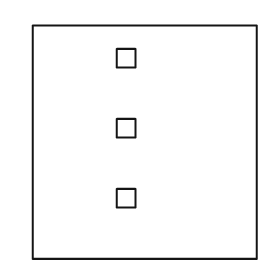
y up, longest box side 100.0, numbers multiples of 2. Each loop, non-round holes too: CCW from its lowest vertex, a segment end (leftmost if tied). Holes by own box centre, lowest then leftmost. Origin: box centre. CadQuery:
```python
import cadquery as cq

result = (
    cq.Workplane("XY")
    .moveTo(-48.0, -50.0)
    .lineTo(48.0, -50.0)
    .lineTo(48.0, 50.0)
    .lineTo(-48.0, 50.0)
    .close()
    .moveTo(-12.0, -28.0)
    .lineTo(-4.0, -28.0)
    .lineTo(-4.0, -20.0)
    .lineTo(-12.0, -20.0)
    .close()
    .moveTo(-12.0, 2.0)
    .lineTo(-4.0, 2.0)
    .lineTo(-4.0, 10.0)
    .lineTo(-12.0, 10.0)
    .close()
    .moveTo(-12.0, 32.0)
    .lineTo(-4.0, 32.0)
    .lineTo(-4.0, 40.0)
    .lineTo(-12.0, 40.0)
    .close()
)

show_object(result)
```